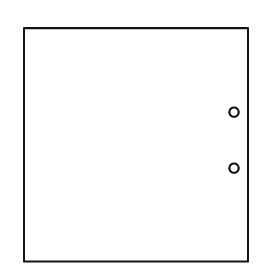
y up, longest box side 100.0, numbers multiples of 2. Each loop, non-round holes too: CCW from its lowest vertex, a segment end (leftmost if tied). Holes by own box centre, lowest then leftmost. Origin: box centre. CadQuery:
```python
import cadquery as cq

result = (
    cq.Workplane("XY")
    .moveTo(-48.0, -50.0)
    .lineTo(48.0, -50.0)
    .lineTo(48.0, 50.0)
    .lineTo(-48.0, 50.0)
    .close()
    .moveTo(42.0, -10.0)
    .circle(2.0)
    .moveTo(42.0, 14.0)
    .circle(2.0)
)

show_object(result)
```